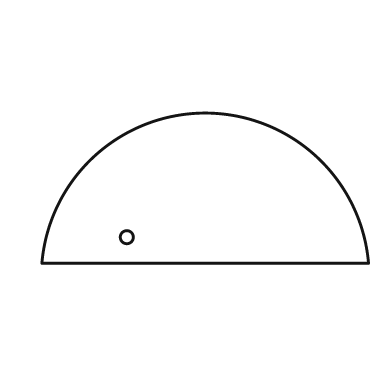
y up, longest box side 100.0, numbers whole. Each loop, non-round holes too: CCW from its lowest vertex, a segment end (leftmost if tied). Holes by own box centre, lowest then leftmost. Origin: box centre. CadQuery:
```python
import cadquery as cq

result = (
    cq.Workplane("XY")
    .moveTo(-50.0, -23.0)
    .lineTo(50.0, -23.0)
    .threePointArc((0.0, 23.0), (-50.0, -23.0))
    .close()
    .moveTo(-24.0, -15.0)
    .circle(2.0)
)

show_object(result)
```